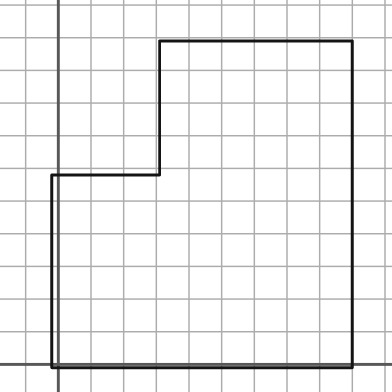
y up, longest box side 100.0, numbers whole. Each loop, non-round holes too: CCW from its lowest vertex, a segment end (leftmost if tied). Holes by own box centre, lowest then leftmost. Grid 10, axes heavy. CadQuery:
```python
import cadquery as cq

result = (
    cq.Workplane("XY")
    .moveTo(-2.0, -1.0)
    .lineTo(90.0, -1.0)
    .lineTo(90.0, 99.0)
    .lineTo(31.0, 99.0)
    .lineTo(31.0, 58.0)
    .lineTo(-2.0, 58.0)
    .close()
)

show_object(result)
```